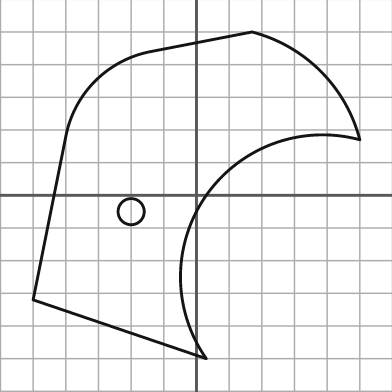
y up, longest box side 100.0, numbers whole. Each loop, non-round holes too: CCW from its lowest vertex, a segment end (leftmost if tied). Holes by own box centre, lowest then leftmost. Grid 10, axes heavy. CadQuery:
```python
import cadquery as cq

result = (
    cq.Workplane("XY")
    .moveTo(3.0, -50.0)
    .threePointArc((3.0, 0.0), (50.0, 17.0))
    .threePointArc((38.0, 38.0), (17.0, 50.0))
    .lineTo(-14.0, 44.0)
    .threePointArc((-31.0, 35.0), (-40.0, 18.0))
    .lineTo(-50.0, -32.0)
    .close()
    .moveTo(-20.0, -5.0)
    .circle(4.0)
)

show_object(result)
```